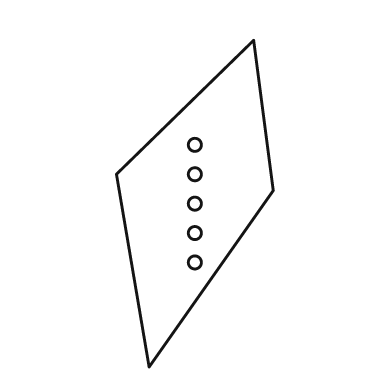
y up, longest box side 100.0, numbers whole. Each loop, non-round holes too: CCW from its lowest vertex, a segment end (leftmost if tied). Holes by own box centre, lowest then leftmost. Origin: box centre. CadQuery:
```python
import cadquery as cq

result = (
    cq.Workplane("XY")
    .moveTo(-14.0, -50.0)
    .lineTo(24.0, 4.0)
    .lineTo(18.0, 50.0)
    .lineTo(-24.0, 9.0)
    .close()
    .moveTo(0.0, -18.0)
    .circle(2.0)
    .moveTo(0.0, -9.0)
    .circle(2.0)
    .moveTo(0.0, 0.0)
    .circle(2.0)
    .moveTo(0.0, 9.0)
    .circle(2.0)
    .moveTo(0.0, 18.0)
    .circle(2.0)
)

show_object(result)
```